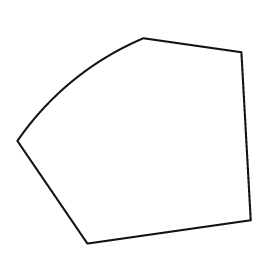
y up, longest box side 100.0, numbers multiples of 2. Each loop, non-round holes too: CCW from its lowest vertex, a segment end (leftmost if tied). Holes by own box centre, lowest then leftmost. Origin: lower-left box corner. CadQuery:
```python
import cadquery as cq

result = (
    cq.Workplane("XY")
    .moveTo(30.0, 0.0)
    .lineTo(100.0, 10.0)
    .lineTo(96.0, 82.0)
    .lineTo(54.0, 88.0)
    .threePointArc((24.0, 70.0), (0.0, 44.0))
    .close()
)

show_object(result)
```